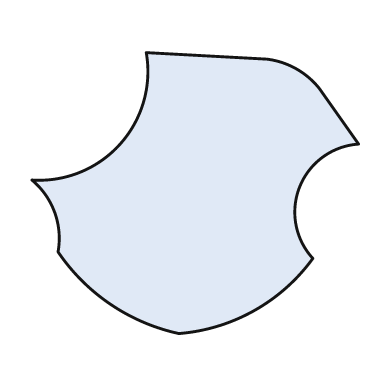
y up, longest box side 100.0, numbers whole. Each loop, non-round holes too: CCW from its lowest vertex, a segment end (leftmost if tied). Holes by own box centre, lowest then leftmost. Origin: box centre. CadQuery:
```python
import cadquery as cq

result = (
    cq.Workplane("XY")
    .moveTo(-5.0, -43.0)
    .threePointArc((18.0, -36.0), (36.0, -20.0))
    .threePointArc((32.0, 2.0), (50.0, 15.0))
    .lineTo(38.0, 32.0)
    .threePointArc((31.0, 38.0), (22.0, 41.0))
    .lineTo(-15.0, 43.0)
    .threePointArc((-23.0, 15.0), (-50.0, 4.0))
    .threePointArc((-43.0, -6.0), (-42.0, -18.0))
    .threePointArc((-26.0, -34.0), (-5.0, -43.0))
    .close()
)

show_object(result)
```